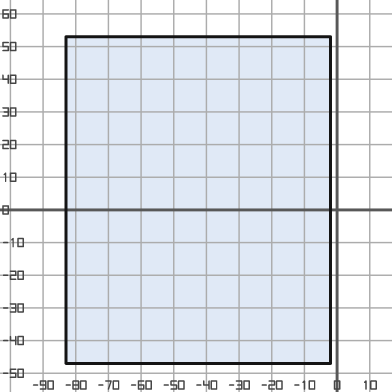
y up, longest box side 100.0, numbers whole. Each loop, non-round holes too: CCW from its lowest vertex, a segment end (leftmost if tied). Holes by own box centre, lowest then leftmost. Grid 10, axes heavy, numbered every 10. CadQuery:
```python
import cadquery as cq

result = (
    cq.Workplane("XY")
    .moveTo(-83.0, -47.0)
    .lineTo(-2.0, -47.0)
    .lineTo(-2.0, 53.0)
    .lineTo(-83.0, 53.0)
    .close()
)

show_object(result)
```